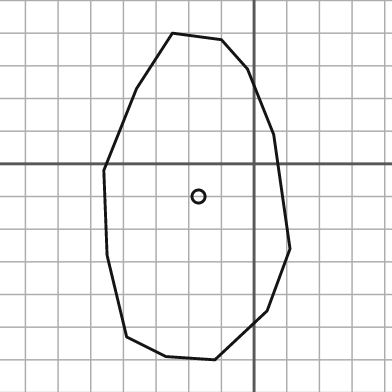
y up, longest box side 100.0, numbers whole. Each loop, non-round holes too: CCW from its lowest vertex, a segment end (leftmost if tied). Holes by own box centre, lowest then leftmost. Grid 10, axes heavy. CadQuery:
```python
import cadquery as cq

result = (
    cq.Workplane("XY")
    .moveTo(-12.0, -60.0)
    .lineTo(4.0, -45.0)
    .lineTo(11.0, -26.0)
    .lineTo(6.0, 9.0)
    .lineTo(-2.0, 29.0)
    .lineTo(-10.0, 38.0)
    .lineTo(-25.0, 40.0)
    .lineTo(-36.0, 23.0)
    .lineTo(-46.0, -2.0)
    .lineTo(-45.0, -28.0)
    .lineTo(-39.0, -53.0)
    .lineTo(-27.0, -59.0)
    .close()
    .moveTo(-17.0, -10.0)
    .circle(2.0)
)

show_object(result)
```